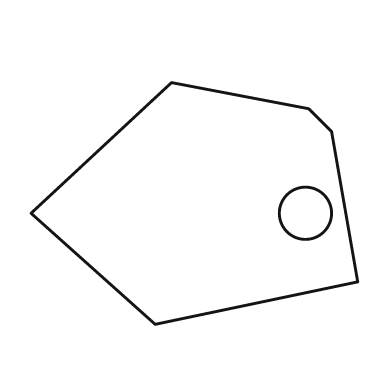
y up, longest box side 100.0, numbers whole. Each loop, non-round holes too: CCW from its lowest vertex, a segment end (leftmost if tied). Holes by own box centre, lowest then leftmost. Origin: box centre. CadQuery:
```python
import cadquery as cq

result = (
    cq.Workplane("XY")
    .moveTo(-12.0, -37.0)
    .lineTo(50.0, -24.0)
    .lineTo(42.0, 22.0)
    .lineTo(35.0, 29.0)
    .lineTo(-7.0, 37.0)
    .lineTo(-50.0, -3.0)
    .close()
    .moveTo(34.0, -3.0)
    .circle(8.0)
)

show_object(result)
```